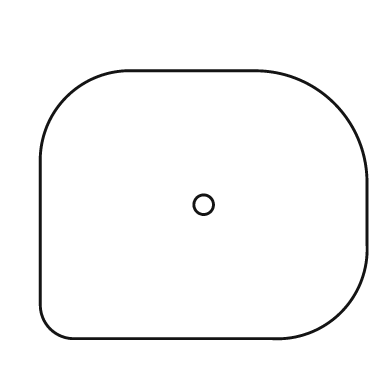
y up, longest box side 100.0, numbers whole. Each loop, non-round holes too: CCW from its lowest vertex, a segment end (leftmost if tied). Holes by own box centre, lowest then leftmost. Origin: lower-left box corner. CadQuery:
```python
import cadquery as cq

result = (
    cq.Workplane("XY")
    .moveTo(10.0, 0.0)
    .lineTo(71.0, 0.0)
    .threePointArc((92.0, 8.0), (100.0, 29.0))
    .lineTo(100.0, 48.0)
    .threePointArc((90.0, 72.0), (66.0, 82.0))
    .lineTo(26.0, 82.0)
    .threePointArc((8.0, 74.0), (0.0, 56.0))
    .lineTo(0.0, 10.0)
    .threePointArc((3.0, 3.0), (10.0, 0.0))
    .close()
    .moveTo(50.0, 41.0)
    .circle(3.0)
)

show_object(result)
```